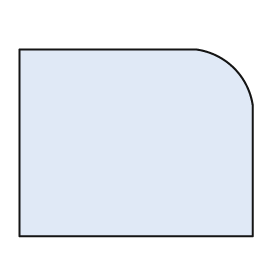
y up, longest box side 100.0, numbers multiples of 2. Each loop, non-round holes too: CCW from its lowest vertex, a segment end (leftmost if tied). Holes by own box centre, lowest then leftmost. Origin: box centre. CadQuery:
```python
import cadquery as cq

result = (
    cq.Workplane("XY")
    .moveTo(-50.0, -40.0)
    .lineTo(50.0, -40.0)
    .lineTo(50.0, 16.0)
    .threePointArc((42.0, 32.0), (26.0, 40.0))
    .lineTo(-50.0, 40.0)
    .close()
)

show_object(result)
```